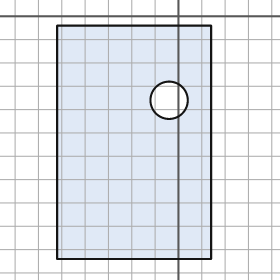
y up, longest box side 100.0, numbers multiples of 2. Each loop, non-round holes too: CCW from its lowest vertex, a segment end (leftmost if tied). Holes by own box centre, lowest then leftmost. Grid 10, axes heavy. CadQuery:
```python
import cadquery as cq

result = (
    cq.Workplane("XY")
    .moveTo(-52.0, -104.0)
    .lineTo(14.0, -104.0)
    .lineTo(14.0, -4.0)
    .lineTo(-52.0, -4.0)
    .close()
    .moveTo(-4.0, -36.0)
    .circle(8.0)
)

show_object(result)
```